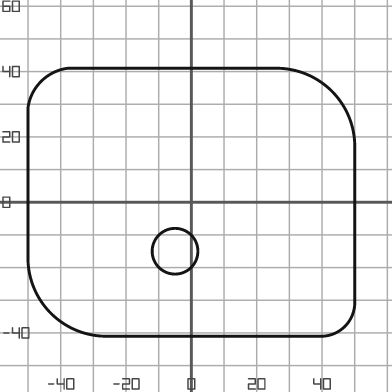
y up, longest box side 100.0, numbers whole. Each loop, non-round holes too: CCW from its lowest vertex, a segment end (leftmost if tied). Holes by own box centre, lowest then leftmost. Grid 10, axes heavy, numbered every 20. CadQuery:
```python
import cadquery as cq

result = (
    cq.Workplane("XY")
    .moveTo(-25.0, -41.0)
    .lineTo(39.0, -41.0)
    .threePointArc((47.0, -38.0), (50.0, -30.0))
    .lineTo(50.0, 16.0)
    .threePointArc((43.0, 34.0), (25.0, 41.0))
    .lineTo(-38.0, 41.0)
    .threePointArc((-46.0, 37.0), (-50.0, 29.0))
    .lineTo(-50.0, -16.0)
    .threePointArc((-43.0, -34.0), (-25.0, -41.0))
    .close()
    .moveTo(-5.0, -15.0)
    .circle(7.0)
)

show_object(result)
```